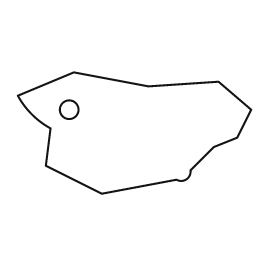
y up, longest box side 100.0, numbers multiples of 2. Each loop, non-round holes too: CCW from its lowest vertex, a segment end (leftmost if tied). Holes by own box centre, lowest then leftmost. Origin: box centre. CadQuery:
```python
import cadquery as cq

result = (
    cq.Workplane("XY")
    .moveTo(-14.0, -26.0)
    .lineTo(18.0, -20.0)
    .threePointArc((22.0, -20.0), (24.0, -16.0))
    .lineTo(34.0, -6.0)
    .lineTo(44.0, -2.0)
    .lineTo(50.0, 10.0)
    .lineTo(36.0, 22.0)
    .lineTo(6.0, 20.0)
    .lineTo(-26.0, 26.0)
    .lineTo(-50.0, 16.0)
    .threePointArc((-44.0, 8.0), (-36.0, 2.0))
    .lineTo(-38.0, -14.0)
    .close()
    .moveTo(-28.0, 10.0)
    .circle(4.0)
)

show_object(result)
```